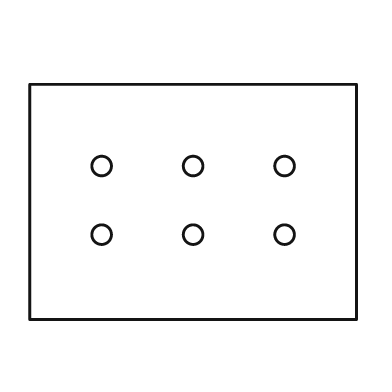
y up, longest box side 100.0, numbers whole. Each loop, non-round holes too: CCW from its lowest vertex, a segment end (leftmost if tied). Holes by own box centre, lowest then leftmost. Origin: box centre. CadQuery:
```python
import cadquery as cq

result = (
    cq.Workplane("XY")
    .moveTo(-50.0, -36.0)
    .lineTo(50.0, -36.0)
    .lineTo(50.0, 36.0)
    .lineTo(-50.0, 36.0)
    .close()
    .moveTo(-28.0, -10.0)
    .circle(3.0)
    .moveTo(0.0, -10.0)
    .circle(3.0)
    .moveTo(28.0, -10.0)
    .circle(3.0)
    .moveTo(-28.0, 11.0)
    .circle(3.0)
    .moveTo(0.0, 11.0)
    .circle(3.0)
    .moveTo(28.0, 11.0)
    .circle(3.0)
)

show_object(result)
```